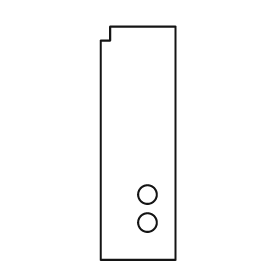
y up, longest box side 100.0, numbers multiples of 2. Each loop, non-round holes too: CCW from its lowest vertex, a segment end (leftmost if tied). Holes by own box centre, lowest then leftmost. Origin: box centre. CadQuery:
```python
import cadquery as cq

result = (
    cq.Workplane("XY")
    .moveTo(-16.0, -50.0)
    .lineTo(16.0, -50.0)
    .lineTo(16.0, 50.0)
    .lineTo(-12.0, 50.0)
    .lineTo(-12.0, 44.0)
    .lineTo(-16.0, 44.0)
    .close()
    .moveTo(4.0, -34.0)
    .circle(4.0)
    .moveTo(4.0, -22.0)
    .circle(4.0)
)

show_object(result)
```